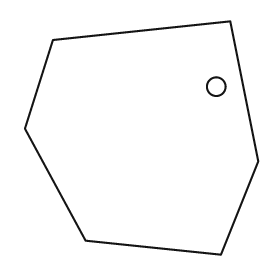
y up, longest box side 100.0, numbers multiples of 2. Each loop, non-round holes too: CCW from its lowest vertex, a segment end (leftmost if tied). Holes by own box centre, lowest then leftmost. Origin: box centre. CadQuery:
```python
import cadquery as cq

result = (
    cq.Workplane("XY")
    .moveTo(34.0, -50.0)
    .lineTo(50.0, -10.0)
    .lineTo(38.0, 50.0)
    .lineTo(-38.0, 42.0)
    .lineTo(-50.0, 4.0)
    .lineTo(-24.0, -44.0)
    .close()
    .moveTo(32.0, 22.0)
    .circle(4.0)
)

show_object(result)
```